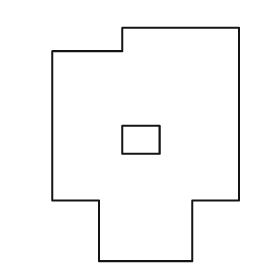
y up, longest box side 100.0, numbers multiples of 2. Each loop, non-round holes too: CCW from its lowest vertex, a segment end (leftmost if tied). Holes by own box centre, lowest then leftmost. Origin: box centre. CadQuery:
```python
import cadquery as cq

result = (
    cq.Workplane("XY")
    .moveTo(-20.0, -50.0)
    .lineTo(20.0, -50.0)
    .lineTo(20.0, -24.0)
    .lineTo(40.0, -24.0)
    .lineTo(40.0, 50.0)
    .lineTo(-10.0, 50.0)
    .lineTo(-10.0, 40.0)
    .lineTo(-40.0, 40.0)
    .lineTo(-40.0, -24.0)
    .lineTo(-20.0, -24.0)
    .close()
    .moveTo(-10.0, -4.0)
    .lineTo(6.0, -4.0)
    .lineTo(6.0, 8.0)
    .lineTo(-10.0, 8.0)
    .close()
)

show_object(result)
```